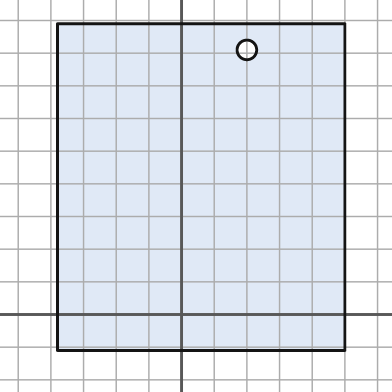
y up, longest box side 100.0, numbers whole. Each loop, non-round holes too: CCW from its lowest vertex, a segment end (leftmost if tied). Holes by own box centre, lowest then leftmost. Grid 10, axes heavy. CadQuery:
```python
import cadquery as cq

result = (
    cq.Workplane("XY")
    .moveTo(-38.0, -11.0)
    .lineTo(50.0, -11.0)
    .lineTo(50.0, 89.0)
    .lineTo(-38.0, 89.0)
    .close()
    .moveTo(20.0, 81.0)
    .circle(3.0)
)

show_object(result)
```